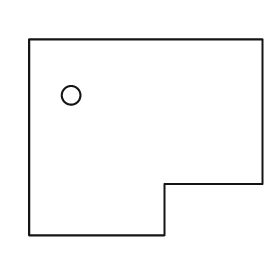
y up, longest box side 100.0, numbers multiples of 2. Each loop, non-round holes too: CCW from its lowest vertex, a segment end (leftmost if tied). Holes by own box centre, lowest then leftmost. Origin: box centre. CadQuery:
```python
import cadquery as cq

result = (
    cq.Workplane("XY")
    .moveTo(-50.0, -42.0)
    .lineTo(8.0, -42.0)
    .lineTo(8.0, -20.0)
    .lineTo(50.0, -20.0)
    .lineTo(50.0, 42.0)
    .lineTo(-50.0, 42.0)
    .close()
    .moveTo(-32.0, 18.0)
    .circle(4.0)
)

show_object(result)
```